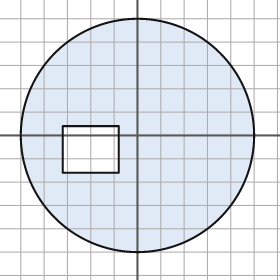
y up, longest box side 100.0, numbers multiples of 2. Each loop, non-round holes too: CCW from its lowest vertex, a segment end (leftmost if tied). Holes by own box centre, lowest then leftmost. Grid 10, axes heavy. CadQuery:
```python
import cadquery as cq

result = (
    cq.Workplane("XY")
    .moveTo(0.0, 0.0)
    .circle(50.0)
    .moveTo(-32.0, -16.0)
    .lineTo(-8.0, -16.0)
    .lineTo(-8.0, 4.0)
    .lineTo(-32.0, 4.0)
    .close()
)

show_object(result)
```